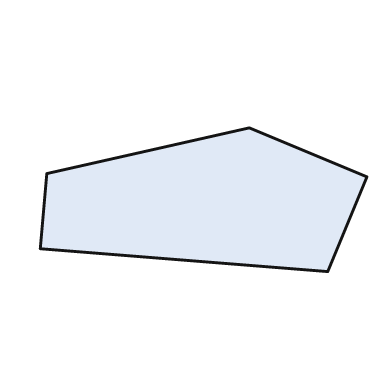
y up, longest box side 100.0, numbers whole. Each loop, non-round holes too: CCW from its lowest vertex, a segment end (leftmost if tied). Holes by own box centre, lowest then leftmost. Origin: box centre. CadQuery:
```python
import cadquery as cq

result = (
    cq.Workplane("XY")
    .moveTo(38.0, -22.0)
    .lineTo(50.0, 7.0)
    .lineTo(14.0, 22.0)
    .lineTo(-48.0, 8.0)
    .lineTo(-50.0, -15.0)
    .close()
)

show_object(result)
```